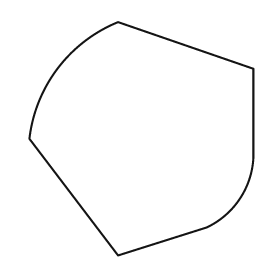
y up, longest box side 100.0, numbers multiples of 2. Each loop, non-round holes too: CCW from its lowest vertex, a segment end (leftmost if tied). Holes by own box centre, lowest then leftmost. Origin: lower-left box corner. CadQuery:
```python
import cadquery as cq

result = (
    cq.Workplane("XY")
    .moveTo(38.0, 0.0)
    .lineTo(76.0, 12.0)
    .threePointArc((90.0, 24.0), (96.0, 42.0))
    .lineTo(96.0, 80.0)
    .lineTo(38.0, 100.0)
    .threePointArc((12.0, 80.0), (0.0, 50.0))
    .close()
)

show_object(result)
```